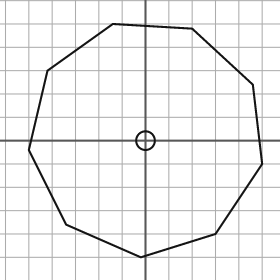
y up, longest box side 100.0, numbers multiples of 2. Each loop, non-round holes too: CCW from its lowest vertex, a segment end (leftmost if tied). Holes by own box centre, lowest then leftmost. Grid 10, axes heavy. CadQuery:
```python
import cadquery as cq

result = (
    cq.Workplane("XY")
    .moveTo(-2.0, -50.0)
    .lineTo(30.0, -40.0)
    .lineTo(50.0, -10.0)
    .lineTo(46.0, 24.0)
    .lineTo(20.0, 48.0)
    .lineTo(-14.0, 50.0)
    .lineTo(-42.0, 30.0)
    .lineTo(-50.0, -4.0)
    .lineTo(-34.0, -36.0)
    .close()
    .moveTo(0.0, 0.0)
    .circle(4.0)
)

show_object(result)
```